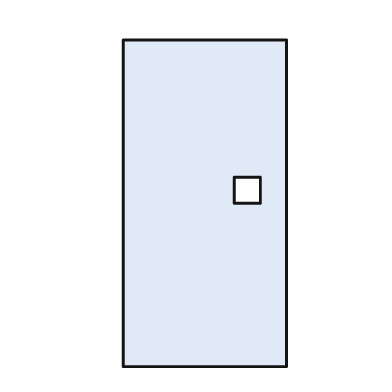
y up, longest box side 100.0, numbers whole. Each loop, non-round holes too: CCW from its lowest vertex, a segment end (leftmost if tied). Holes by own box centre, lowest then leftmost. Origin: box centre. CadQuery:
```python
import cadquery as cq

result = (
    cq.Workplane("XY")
    .moveTo(-25.0, -50.0)
    .lineTo(25.0, -50.0)
    .lineTo(25.0, 50.0)
    .lineTo(-25.0, 50.0)
    .close()
    .moveTo(9.0, 0.0)
    .lineTo(17.0, 0.0)
    .lineTo(17.0, 8.0)
    .lineTo(9.0, 8.0)
    .close()
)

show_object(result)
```